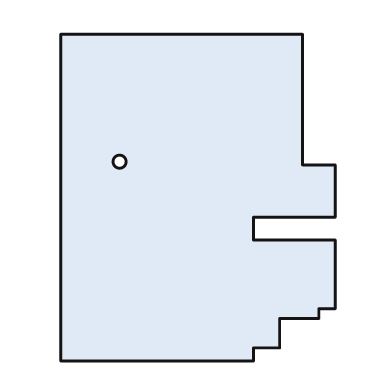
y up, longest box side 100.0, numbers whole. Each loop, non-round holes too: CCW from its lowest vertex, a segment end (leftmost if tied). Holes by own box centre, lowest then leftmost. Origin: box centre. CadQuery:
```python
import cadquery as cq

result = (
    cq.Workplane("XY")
    .moveTo(-42.0, -50.0)
    .lineTo(17.0, -50.0)
    .lineTo(17.0, -46.0)
    .lineTo(25.0, -46.0)
    .lineTo(25.0, -37.0)
    .lineTo(37.0, -37.0)
    .lineTo(37.0, -34.0)
    .lineTo(42.0, -34.0)
    .lineTo(42.0, -13.0)
    .lineTo(17.0, -13.0)
    .lineTo(17.0, -6.0)
    .lineTo(42.0, -6.0)
    .lineTo(42.0, 10.0)
    .lineTo(32.0, 10.0)
    .lineTo(32.0, 50.0)
    .lineTo(-42.0, 50.0)
    .close()
    .moveTo(-24.0, 11.0)
    .circle(2.0)
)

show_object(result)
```